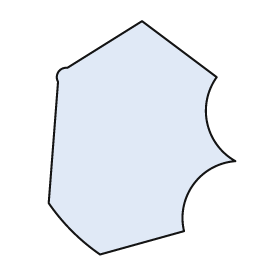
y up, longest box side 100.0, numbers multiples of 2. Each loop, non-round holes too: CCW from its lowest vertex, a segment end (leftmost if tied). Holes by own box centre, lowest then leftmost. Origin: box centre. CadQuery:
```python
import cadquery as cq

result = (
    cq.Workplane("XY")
    .moveTo(-18.0, -50.0)
    .lineTo(18.0, -40.0)
    .threePointArc((22.0, -20.0), (40.0, -10.0))
    .threePointArc((28.0, 6.0), (32.0, 26.0))
    .lineTo(0.0, 50.0)
    .lineTo(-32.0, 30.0)
    .threePointArc((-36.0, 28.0), (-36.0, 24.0))
    .lineTo(-40.0, -28.0)
    .threePointArc((-30.0, -40.0), (-18.0, -50.0))
    .close()
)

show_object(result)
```